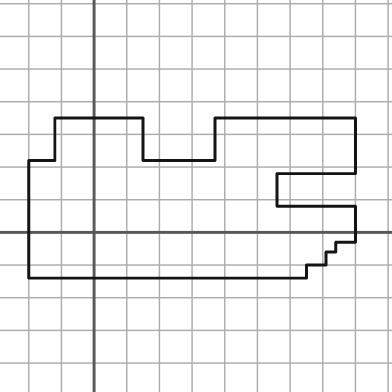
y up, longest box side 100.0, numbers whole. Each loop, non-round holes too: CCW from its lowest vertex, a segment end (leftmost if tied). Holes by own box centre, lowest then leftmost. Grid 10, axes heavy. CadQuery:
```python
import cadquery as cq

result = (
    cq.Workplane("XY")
    .moveTo(-20.0, -14.0)
    .lineTo(65.0, -14.0)
    .lineTo(65.0, -10.0)
    .lineTo(71.0, -10.0)
    .lineTo(71.0, -6.0)
    .lineTo(74.0, -6.0)
    .lineTo(74.0, -3.0)
    .lineTo(80.0, -3.0)
    .lineTo(80.0, 8.0)
    .lineTo(56.0, 8.0)
    .lineTo(56.0, 18.0)
    .lineTo(80.0, 18.0)
    .lineTo(80.0, 35.0)
    .lineTo(37.0, 35.0)
    .lineTo(37.0, 22.0)
    .lineTo(15.0, 22.0)
    .lineTo(15.0, 35.0)
    .lineTo(-12.0, 35.0)
    .lineTo(-12.0, 22.0)
    .lineTo(-20.0, 22.0)
    .close()
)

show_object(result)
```